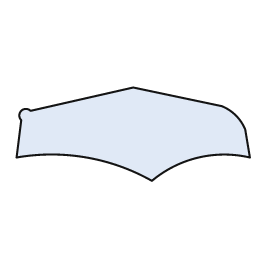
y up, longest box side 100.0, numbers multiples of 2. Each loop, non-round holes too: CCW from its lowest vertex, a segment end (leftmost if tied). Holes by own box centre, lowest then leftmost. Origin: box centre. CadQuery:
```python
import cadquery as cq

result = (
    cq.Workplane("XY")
    .moveTo(8.0, -20.0)
    .threePointArc((28.0, -10.0), (50.0, -10.0))
    .lineTo(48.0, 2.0)
    .threePointArc((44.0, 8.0), (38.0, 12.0))
    .lineTo(0.0, 20.0)
    .lineTo(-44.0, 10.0)
    .threePointArc((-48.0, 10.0), (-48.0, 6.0))
    .lineTo(-50.0, -10.0)
    .threePointArc((-20.0, -10.0), (8.0, -20.0))
    .close()
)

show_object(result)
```